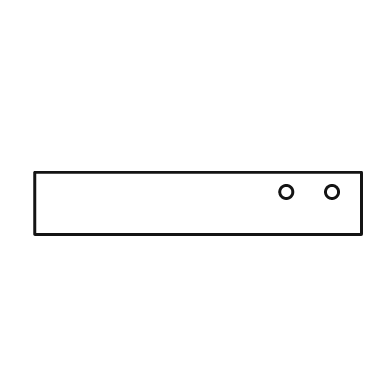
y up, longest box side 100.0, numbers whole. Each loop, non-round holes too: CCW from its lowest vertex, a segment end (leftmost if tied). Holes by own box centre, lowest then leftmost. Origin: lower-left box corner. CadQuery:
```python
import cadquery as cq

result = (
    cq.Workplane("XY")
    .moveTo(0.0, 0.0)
    .lineTo(100.0, 0.0)
    .lineTo(100.0, 19.0)
    .lineTo(0.0, 19.0)
    .close()
    .moveTo(77.0, 13.0)
    .circle(2.0)
    .moveTo(91.0, 13.0)
    .circle(2.0)
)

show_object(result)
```